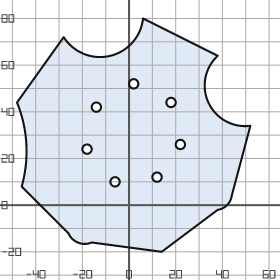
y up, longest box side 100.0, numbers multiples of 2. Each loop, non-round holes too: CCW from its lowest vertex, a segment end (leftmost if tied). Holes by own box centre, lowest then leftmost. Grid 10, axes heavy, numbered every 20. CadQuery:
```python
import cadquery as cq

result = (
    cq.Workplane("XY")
    .moveTo(14.0, -20.0)
    .lineTo(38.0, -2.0)
    .threePointArc((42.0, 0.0), (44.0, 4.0))
    .lineTo(52.0, 34.0)
    .threePointArc((34.0, 44.0), (38.0, 64.0))
    .lineTo(6.0, 80.0)
    .threePointArc((-8.0, 64.0), (-28.0, 72.0))
    .lineTo(-48.0, 44.0)
    .threePointArc((-44.0, 26.0), (-46.0, 8.0))
    .lineTo(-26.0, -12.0)
    .threePointArc((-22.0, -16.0), (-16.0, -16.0))
    .close()
    .moveTo(-6.0, 10.0)
    .circle(2.0)
    .moveTo(12.0, 12.0)
    .circle(2.0)
    .moveTo(-18.0, 24.0)
    .circle(2.0)
    .moveTo(22.0, 26.0)
    .circle(2.0)
    .moveTo(-14.0, 42.0)
    .circle(2.0)
    .moveTo(18.0, 44.0)
    .circle(2.0)
    .moveTo(2.0, 52.0)
    .circle(2.0)
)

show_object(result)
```